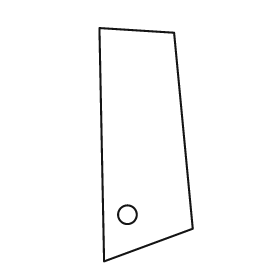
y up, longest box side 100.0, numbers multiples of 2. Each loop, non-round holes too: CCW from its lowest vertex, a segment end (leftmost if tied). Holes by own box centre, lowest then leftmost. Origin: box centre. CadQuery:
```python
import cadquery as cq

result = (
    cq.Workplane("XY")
    .moveTo(-18.0, -50.0)
    .lineTo(20.0, -36.0)
    .lineTo(12.0, 48.0)
    .lineTo(-20.0, 50.0)
    .close()
    .moveTo(-8.0, -30.0)
    .circle(4.0)
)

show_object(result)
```